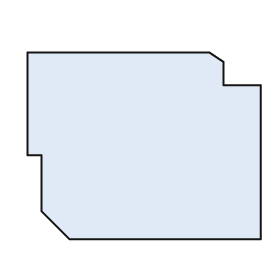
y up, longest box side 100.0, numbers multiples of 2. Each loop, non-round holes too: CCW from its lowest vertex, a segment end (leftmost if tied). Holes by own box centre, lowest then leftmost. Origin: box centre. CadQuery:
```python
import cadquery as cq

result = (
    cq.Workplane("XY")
    .moveTo(-32.0, -40.0)
    .lineTo(50.0, -40.0)
    .lineTo(50.0, 26.0)
    .lineTo(34.0, 26.0)
    .lineTo(34.0, 36.0)
    .lineTo(28.0, 40.0)
    .lineTo(-50.0, 40.0)
    .lineTo(-50.0, -4.0)
    .lineTo(-44.0, -4.0)
    .lineTo(-44.0, -28.0)
    .close()
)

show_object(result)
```